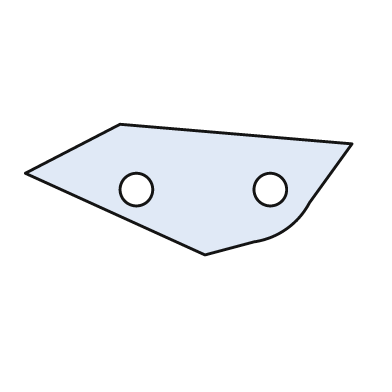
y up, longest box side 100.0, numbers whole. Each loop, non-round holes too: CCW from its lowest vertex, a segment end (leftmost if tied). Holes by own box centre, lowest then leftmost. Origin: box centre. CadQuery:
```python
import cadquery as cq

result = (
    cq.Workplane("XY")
    .moveTo(5.0, -20.0)
    .lineTo(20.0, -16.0)
    .threePointArc((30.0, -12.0), (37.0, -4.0))
    .lineTo(50.0, 14.0)
    .lineTo(-21.0, 20.0)
    .lineTo(-50.0, 5.0)
    .close()
    .moveTo(-16.0, 0.0)
    .circle(5.0)
    .moveTo(25.0, 0.0)
    .circle(5.0)
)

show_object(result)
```